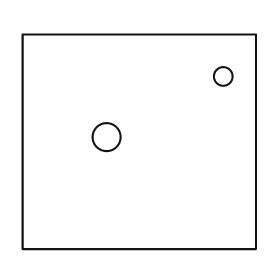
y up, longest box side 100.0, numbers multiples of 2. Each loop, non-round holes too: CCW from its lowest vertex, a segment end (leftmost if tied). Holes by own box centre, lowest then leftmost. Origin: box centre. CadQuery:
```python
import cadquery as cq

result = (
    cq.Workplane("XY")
    .moveTo(-50.0, -46.0)
    .lineTo(50.0, -46.0)
    .lineTo(50.0, 46.0)
    .lineTo(-50.0, 46.0)
    .close()
    .moveTo(-14.0, 2.0)
    .circle(6.0)
    .moveTo(36.0, 28.0)
    .circle(4.0)
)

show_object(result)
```